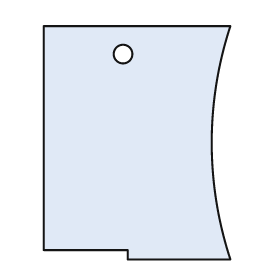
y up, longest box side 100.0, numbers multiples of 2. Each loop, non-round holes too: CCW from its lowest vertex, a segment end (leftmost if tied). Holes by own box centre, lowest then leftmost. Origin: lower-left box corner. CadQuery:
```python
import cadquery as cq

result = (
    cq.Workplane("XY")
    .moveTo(36.0, 0.0)
    .lineTo(80.0, 0.0)
    .threePointArc((72.0, 50.0), (80.0, 100.0))
    .lineTo(0.0, 100.0)
    .lineTo(0.0, 4.0)
    .lineTo(36.0, 4.0)
    .close()
    .moveTo(34.0, 88.0)
    .circle(4.0)
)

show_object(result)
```